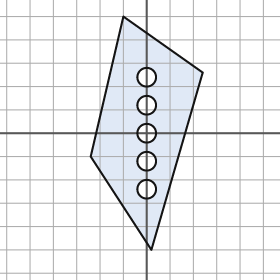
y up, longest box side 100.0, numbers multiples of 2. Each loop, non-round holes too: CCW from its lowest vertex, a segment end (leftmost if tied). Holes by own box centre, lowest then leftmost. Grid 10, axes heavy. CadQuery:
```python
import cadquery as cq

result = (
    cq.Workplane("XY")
    .moveTo(2.0, -50.0)
    .lineTo(24.0, 26.0)
    .lineTo(-10.0, 50.0)
    .lineTo(-24.0, -10.0)
    .close()
    .moveTo(0.0, -24.0)
    .circle(4.0)
    .moveTo(0.0, -12.0)
    .circle(4.0)
    .moveTo(0.0, 0.0)
    .circle(4.0)
    .moveTo(0.0, 12.0)
    .circle(4.0)
    .moveTo(0.0, 24.0)
    .circle(4.0)
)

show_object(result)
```